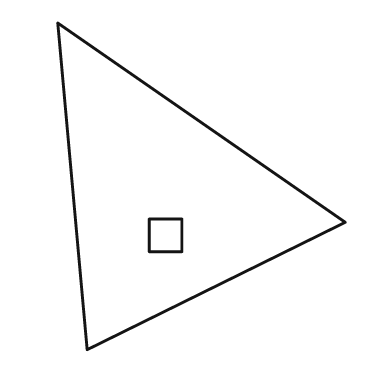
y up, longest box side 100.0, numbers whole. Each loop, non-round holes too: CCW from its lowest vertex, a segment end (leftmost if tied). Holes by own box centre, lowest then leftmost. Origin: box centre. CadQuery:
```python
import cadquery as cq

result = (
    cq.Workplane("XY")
    .moveTo(-35.0, -50.0)
    .lineTo(44.0, -11.0)
    .lineTo(-44.0, 50.0)
    .close()
    .moveTo(-16.0, -20.0)
    .lineTo(-6.0, -20.0)
    .lineTo(-6.0, -10.0)
    .lineTo(-16.0, -10.0)
    .close()
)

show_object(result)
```